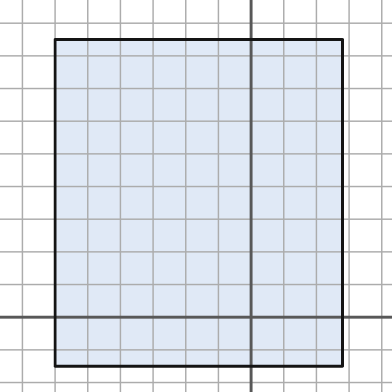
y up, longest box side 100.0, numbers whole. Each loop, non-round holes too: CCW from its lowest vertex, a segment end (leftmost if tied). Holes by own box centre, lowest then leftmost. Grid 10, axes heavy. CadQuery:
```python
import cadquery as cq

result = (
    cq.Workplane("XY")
    .moveTo(-60.0, -15.0)
    .lineTo(28.0, -15.0)
    .lineTo(28.0, 85.0)
    .lineTo(-60.0, 85.0)
    .close()
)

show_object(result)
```